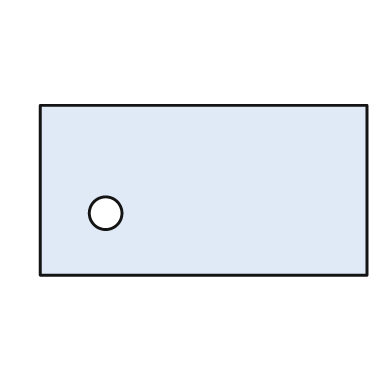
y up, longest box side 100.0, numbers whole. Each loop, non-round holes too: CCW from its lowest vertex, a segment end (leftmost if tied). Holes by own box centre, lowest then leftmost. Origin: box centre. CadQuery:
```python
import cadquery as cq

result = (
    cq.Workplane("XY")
    .moveTo(-50.0, -26.0)
    .lineTo(50.0, -26.0)
    .lineTo(50.0, 26.0)
    .lineTo(-50.0, 26.0)
    .close()
    .moveTo(-30.0, -7.0)
    .circle(5.0)
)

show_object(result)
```